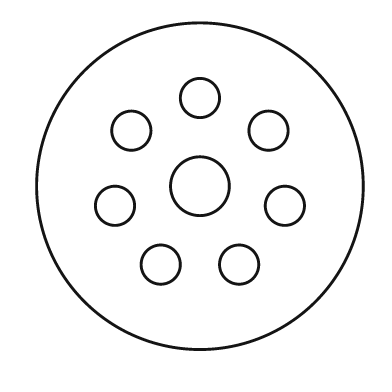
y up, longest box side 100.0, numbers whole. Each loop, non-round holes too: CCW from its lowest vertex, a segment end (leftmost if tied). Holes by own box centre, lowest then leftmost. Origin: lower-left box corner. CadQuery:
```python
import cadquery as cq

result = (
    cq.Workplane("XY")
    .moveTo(50.0, 50.0)
    .circle(50.0)
    .moveTo(38.0, 26.0)
    .circle(6.0)
    .moveTo(62.0, 26.0)
    .circle(6.0)
    .moveTo(24.0, 44.0)
    .circle(6.0)
    .moveTo(76.0, 44.0)
    .circle(6.0)
    .moveTo(50.0, 50.0)
    .circle(9.0)
    .moveTo(29.0, 67.0)
    .circle(6.0)
    .moveTo(71.0, 67.0)
    .circle(6.0)
    .moveTo(50.0, 77.0)
    .circle(6.0)
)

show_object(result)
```